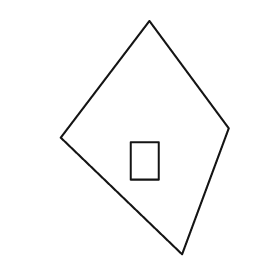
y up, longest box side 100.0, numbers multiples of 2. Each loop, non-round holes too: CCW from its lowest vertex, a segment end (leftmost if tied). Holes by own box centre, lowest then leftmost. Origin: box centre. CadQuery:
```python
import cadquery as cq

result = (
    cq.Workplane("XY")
    .moveTo(16.0, -50.0)
    .lineTo(36.0, 4.0)
    .lineTo(2.0, 50.0)
    .lineTo(-36.0, 0.0)
    .close()
    .moveTo(-6.0, -18.0)
    .lineTo(6.0, -18.0)
    .lineTo(6.0, -2.0)
    .lineTo(-6.0, -2.0)
    .close()
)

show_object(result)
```